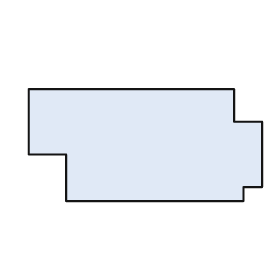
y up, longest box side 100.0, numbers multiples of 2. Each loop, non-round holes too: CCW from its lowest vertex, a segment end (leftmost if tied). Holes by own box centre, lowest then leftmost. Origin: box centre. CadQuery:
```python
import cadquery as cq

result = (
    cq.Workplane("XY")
    .moveTo(-34.0, -24.0)
    .lineTo(42.0, -24.0)
    .lineTo(42.0, -18.0)
    .lineTo(50.0, -18.0)
    .lineTo(50.0, 10.0)
    .lineTo(38.0, 10.0)
    .lineTo(38.0, 24.0)
    .lineTo(-50.0, 24.0)
    .lineTo(-50.0, -4.0)
    .lineTo(-34.0, -4.0)
    .close()
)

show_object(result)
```